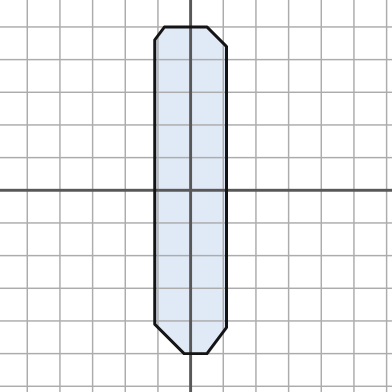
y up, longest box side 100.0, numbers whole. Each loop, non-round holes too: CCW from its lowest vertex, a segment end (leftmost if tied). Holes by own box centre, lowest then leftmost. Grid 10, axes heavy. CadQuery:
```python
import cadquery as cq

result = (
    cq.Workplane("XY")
    .moveTo(-2.0, -50.0)
    .lineTo(5.0, -50.0)
    .lineTo(11.0, -42.0)
    .lineTo(11.0, 44.0)
    .lineTo(5.0, 50.0)
    .lineTo(-8.0, 50.0)
    .lineTo(-11.0, 46.0)
    .lineTo(-11.0, -41.0)
    .close()
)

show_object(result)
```